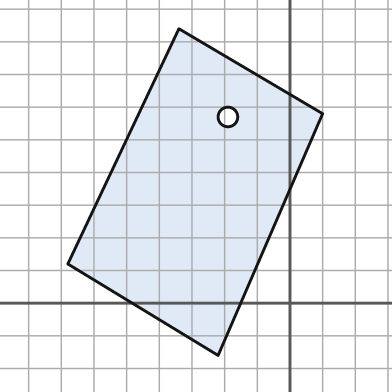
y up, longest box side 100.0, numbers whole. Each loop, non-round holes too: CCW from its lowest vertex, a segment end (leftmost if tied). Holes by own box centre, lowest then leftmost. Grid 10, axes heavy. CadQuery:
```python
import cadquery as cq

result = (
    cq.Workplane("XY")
    .moveTo(-22.0, -16.0)
    .lineTo(10.0, 58.0)
    .lineTo(-34.0, 84.0)
    .lineTo(-68.0, 12.0)
    .close()
    .moveTo(-19.0, 57.0)
    .circle(3.0)
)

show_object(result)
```